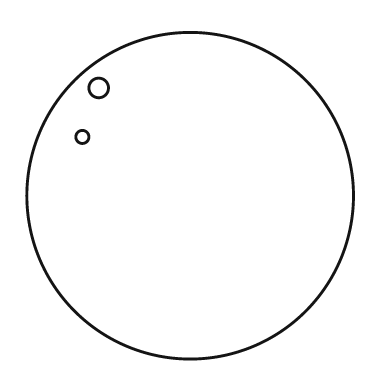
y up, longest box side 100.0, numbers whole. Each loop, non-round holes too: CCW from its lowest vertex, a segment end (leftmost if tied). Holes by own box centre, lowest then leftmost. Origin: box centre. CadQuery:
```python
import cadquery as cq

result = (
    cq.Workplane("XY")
    .moveTo(0.0, 0.0)
    .circle(50.0)
    .moveTo(-33.0, 18.0)
    .circle(2.0)
    .moveTo(-28.0, 33.0)
    .circle(3.0)
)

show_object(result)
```